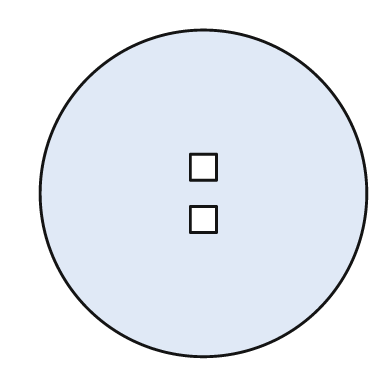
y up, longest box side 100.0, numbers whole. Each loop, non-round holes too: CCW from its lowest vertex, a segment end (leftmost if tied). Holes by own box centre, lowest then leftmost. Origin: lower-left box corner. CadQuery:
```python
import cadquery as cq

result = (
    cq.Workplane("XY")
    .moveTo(50.0, 50.0)
    .circle(50.0)
    .moveTo(46.0, 38.0)
    .lineTo(54.0, 38.0)
    .lineTo(54.0, 46.0)
    .lineTo(46.0, 46.0)
    .close()
    .moveTo(46.0, 54.0)
    .lineTo(54.0, 54.0)
    .lineTo(54.0, 62.0)
    .lineTo(46.0, 62.0)
    .close()
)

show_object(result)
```